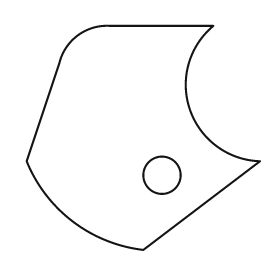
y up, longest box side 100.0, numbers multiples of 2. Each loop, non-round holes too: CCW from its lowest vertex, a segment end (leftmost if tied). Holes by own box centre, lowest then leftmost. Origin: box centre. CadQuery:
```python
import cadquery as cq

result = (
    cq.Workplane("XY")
    .moveTo(0.0, -48.0)
    .lineTo(50.0, -10.0)
    .threePointArc((20.0, 12.0), (30.0, 48.0))
    .lineTo(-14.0, 48.0)
    .threePointArc((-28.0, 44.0), (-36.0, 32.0))
    .lineTo(-50.0, -10.0)
    .threePointArc((-30.0, -36.0), (0.0, -48.0))
    .close()
    .moveTo(8.0, -16.0)
    .circle(8.0)
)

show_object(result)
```